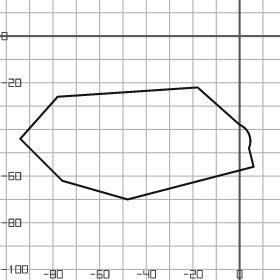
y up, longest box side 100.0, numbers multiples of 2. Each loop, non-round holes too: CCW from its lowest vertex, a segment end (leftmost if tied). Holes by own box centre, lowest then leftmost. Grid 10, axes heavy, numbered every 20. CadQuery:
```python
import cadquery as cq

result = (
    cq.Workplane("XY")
    .moveTo(-48.0, -70.0)
    .lineTo(6.0, -56.0)
    .lineTo(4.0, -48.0)
    .threePointArc((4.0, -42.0), (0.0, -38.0))
    .lineTo(-18.0, -22.0)
    .lineTo(-78.0, -26.0)
    .lineTo(-94.0, -44.0)
    .lineTo(-76.0, -62.0)
    .close()
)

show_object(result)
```